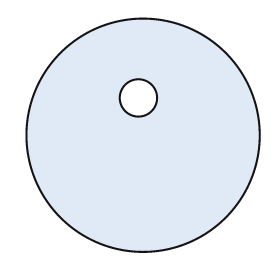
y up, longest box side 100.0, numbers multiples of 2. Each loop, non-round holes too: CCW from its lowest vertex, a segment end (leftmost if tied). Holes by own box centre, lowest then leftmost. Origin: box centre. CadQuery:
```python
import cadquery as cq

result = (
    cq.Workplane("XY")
    .moveTo(0.0, 0.0)
    .circle(50.0)
    .moveTo(-2.0, 16.0)
    .circle(8.0)
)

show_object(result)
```